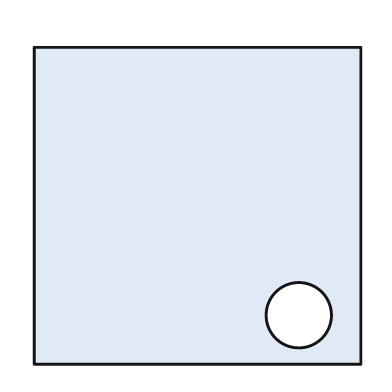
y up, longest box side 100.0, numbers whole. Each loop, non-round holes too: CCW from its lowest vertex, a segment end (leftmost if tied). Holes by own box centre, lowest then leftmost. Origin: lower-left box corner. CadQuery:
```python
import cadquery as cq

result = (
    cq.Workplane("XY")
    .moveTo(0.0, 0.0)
    .lineTo(100.0, 0.0)
    .lineTo(100.0, 97.0)
    .lineTo(0.0, 97.0)
    .close()
    .moveTo(81.0, 15.0)
    .circle(10.0)
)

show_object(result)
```